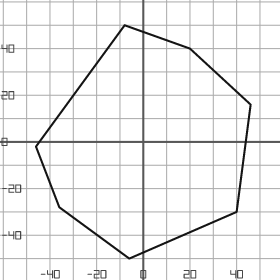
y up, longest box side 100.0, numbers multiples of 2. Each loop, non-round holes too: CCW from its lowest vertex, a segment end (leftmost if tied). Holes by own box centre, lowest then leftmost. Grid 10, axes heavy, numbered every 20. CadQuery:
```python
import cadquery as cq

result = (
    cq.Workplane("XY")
    .moveTo(-6.0, -50.0)
    .lineTo(40.0, -30.0)
    .lineTo(46.0, 16.0)
    .lineTo(20.0, 40.0)
    .lineTo(-8.0, 50.0)
    .lineTo(-46.0, -2.0)
    .lineTo(-36.0, -28.0)
    .close()
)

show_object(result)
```